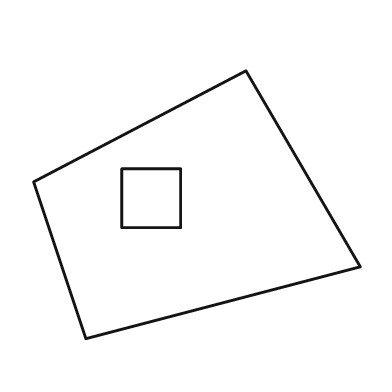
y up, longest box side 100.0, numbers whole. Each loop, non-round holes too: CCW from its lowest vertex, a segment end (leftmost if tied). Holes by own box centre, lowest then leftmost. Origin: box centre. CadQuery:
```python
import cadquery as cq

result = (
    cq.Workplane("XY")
    .moveTo(-34.0, -41.0)
    .lineTo(50.0, -19.0)
    .lineTo(15.0, 41.0)
    .lineTo(-50.0, 7.0)
    .close()
    .moveTo(-23.0, -7.0)
    .lineTo(-5.0, -7.0)
    .lineTo(-5.0, 11.0)
    .lineTo(-23.0, 11.0)
    .close()
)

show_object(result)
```